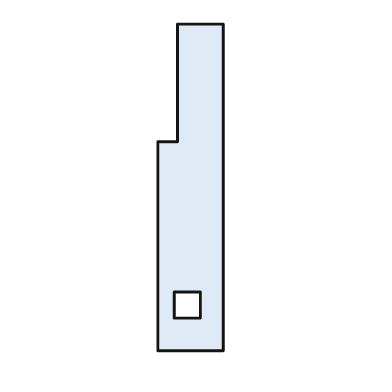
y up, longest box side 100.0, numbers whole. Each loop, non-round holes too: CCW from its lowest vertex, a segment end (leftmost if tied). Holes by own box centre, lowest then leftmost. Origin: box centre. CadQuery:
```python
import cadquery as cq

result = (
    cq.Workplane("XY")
    .moveTo(-10.0, -50.0)
    .lineTo(10.0, -50.0)
    .lineTo(10.0, 50.0)
    .lineTo(-4.0, 50.0)
    .lineTo(-4.0, 14.0)
    .lineTo(-10.0, 14.0)
    .close()
    .moveTo(-5.0, -40.0)
    .lineTo(3.0, -40.0)
    .lineTo(3.0, -32.0)
    .lineTo(-5.0, -32.0)
    .close()
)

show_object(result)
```